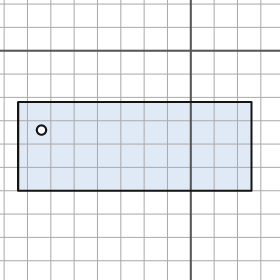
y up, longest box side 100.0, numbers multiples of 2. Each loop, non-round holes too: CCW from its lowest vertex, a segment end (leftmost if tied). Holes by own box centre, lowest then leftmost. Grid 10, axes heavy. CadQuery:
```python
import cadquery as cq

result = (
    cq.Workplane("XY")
    .moveTo(-74.0, -60.0)
    .lineTo(26.0, -60.0)
    .lineTo(26.0, -22.0)
    .lineTo(-74.0, -22.0)
    .close()
    .moveTo(-64.0, -34.0)
    .circle(2.0)
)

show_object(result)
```